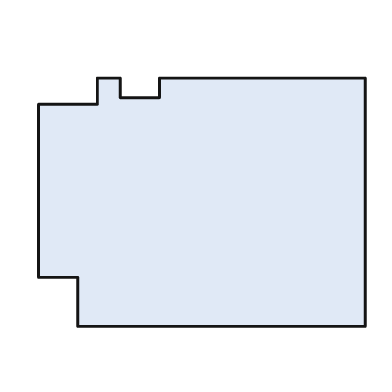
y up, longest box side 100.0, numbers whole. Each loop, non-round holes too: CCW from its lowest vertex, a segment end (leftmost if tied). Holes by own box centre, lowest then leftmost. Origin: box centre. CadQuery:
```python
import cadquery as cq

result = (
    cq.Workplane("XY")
    .moveTo(-38.0, -38.0)
    .lineTo(50.0, -38.0)
    .lineTo(50.0, 38.0)
    .lineTo(-13.0, 38.0)
    .lineTo(-13.0, 32.0)
    .lineTo(-25.0, 32.0)
    .lineTo(-25.0, 38.0)
    .lineTo(-32.0, 38.0)
    .lineTo(-32.0, 30.0)
    .lineTo(-50.0, 30.0)
    .lineTo(-50.0, -23.0)
    .lineTo(-38.0, -23.0)
    .close()
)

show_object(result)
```